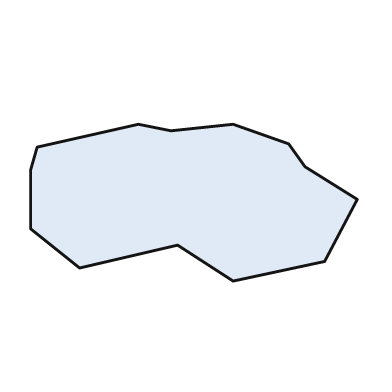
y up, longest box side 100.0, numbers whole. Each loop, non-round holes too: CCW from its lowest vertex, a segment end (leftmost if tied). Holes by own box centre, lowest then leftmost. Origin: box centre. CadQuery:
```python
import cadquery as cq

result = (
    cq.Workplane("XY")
    .moveTo(12.0, -24.0)
    .lineTo(40.0, -18.0)
    .lineTo(50.0, 1.0)
    .lineTo(34.0, 11.0)
    .lineTo(29.0, 18.0)
    .lineTo(12.0, 24.0)
    .lineTo(-7.0, 22.0)
    .lineTo(-17.0, 24.0)
    .lineTo(-48.0, 17.0)
    .lineTo(-50.0, 10.0)
    .lineTo(-50.0, -8.0)
    .lineTo(-35.0, -20.0)
    .lineTo(-5.0, -13.0)
    .close()
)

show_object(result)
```